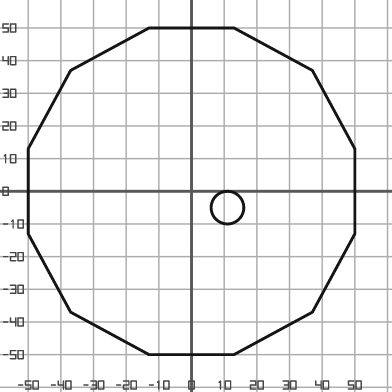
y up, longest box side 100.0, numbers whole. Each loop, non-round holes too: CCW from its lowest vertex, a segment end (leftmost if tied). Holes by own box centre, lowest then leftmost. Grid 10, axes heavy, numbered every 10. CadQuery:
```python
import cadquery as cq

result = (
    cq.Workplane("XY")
    .moveTo(-13.0, -50.0)
    .lineTo(13.0, -50.0)
    .lineTo(37.0, -37.0)
    .lineTo(50.0, -13.0)
    .lineTo(50.0, 13.0)
    .lineTo(37.0, 37.0)
    .lineTo(13.0, 50.0)
    .lineTo(-13.0, 50.0)
    .lineTo(-37.0, 37.0)
    .lineTo(-50.0, 13.0)
    .lineTo(-50.0, -13.0)
    .lineTo(-37.0, -37.0)
    .close()
    .moveTo(11.0, -5.0)
    .circle(5.0)
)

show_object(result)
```